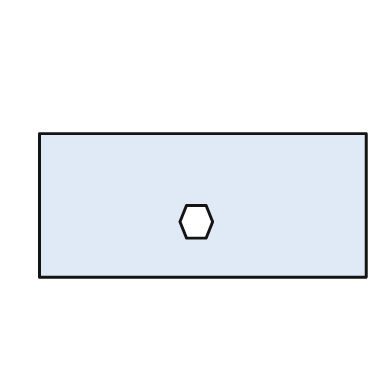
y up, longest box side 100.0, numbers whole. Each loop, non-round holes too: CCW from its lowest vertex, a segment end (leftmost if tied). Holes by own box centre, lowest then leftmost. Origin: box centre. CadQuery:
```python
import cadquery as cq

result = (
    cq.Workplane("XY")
    .moveTo(-50.0, -22.0)
    .lineTo(50.0, -22.0)
    .lineTo(50.0, 22.0)
    .lineTo(-50.0, 22.0)
    .close()
    .moveTo(-5.0, -10.0)
    .lineTo(1.0, -10.0)
    .lineTo(3.0, -5.0)
    .lineTo(1.0, 0.0)
    .lineTo(-5.0, 0.0)
    .lineTo(-7.0, -5.0)
    .close()
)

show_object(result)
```